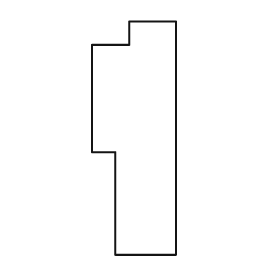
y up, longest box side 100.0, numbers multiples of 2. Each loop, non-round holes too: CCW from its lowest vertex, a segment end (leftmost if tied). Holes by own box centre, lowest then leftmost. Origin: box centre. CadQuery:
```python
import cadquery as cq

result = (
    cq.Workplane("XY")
    .moveTo(-8.0, -50.0)
    .lineTo(18.0, -50.0)
    .lineTo(18.0, 50.0)
    .lineTo(-2.0, 50.0)
    .lineTo(-2.0, 40.0)
    .lineTo(-18.0, 40.0)
    .lineTo(-18.0, -6.0)
    .lineTo(-8.0, -6.0)
    .close()
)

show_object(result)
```